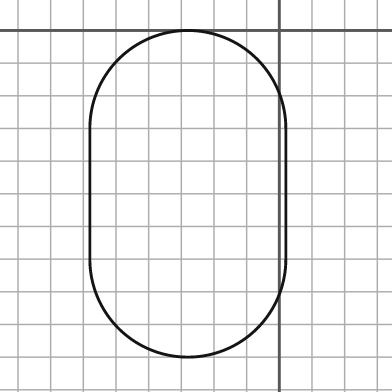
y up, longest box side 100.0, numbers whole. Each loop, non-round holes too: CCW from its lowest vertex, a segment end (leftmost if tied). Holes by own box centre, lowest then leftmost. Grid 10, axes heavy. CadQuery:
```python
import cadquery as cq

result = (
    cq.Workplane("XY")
    .moveTo(-58.0, -70.0)
    .threePointArc((-28.0, -100.0), (2.0, -70.0))
    .lineTo(2.0, -30.0)
    .threePointArc((-28.0, 0.0), (-58.0, -30.0))
    .close()
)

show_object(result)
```